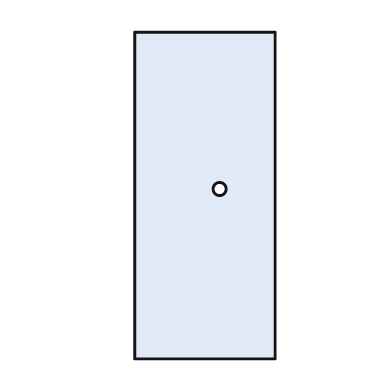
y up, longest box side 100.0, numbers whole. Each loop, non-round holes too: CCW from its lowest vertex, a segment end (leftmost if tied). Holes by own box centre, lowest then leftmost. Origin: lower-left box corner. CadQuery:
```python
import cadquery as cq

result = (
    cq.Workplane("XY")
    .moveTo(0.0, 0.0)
    .lineTo(43.0, 0.0)
    .lineTo(43.0, 100.0)
    .lineTo(0.0, 100.0)
    .close()
    .moveTo(26.0, 52.0)
    .circle(2.0)
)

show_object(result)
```